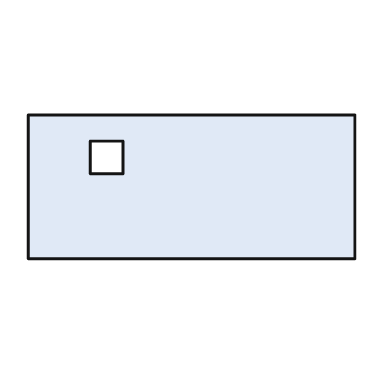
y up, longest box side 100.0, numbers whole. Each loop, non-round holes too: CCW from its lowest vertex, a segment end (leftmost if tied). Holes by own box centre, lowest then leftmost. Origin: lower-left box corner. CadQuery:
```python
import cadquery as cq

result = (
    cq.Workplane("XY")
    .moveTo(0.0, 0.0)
    .lineTo(100.0, 0.0)
    .lineTo(100.0, 44.0)
    .lineTo(0.0, 44.0)
    .close()
    .moveTo(19.0, 26.0)
    .lineTo(29.0, 26.0)
    .lineTo(29.0, 36.0)
    .lineTo(19.0, 36.0)
    .close()
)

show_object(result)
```